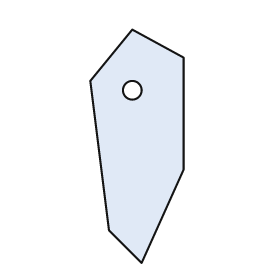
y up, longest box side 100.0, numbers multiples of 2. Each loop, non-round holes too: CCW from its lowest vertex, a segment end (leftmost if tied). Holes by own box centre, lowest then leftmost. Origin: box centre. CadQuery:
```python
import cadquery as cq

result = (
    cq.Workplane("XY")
    .moveTo(2.0, -50.0)
    .lineTo(20.0, -10.0)
    .lineTo(20.0, 38.0)
    .lineTo(-2.0, 50.0)
    .lineTo(-20.0, 28.0)
    .lineTo(-12.0, -36.0)
    .close()
    .moveTo(-2.0, 24.0)
    .circle(4.0)
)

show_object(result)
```